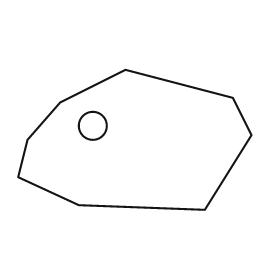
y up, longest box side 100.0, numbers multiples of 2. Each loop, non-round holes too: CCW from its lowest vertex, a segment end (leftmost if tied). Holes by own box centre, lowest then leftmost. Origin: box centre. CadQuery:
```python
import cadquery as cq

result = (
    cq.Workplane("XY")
    .moveTo(30.0, -30.0)
    .lineTo(50.0, 2.0)
    .lineTo(42.0, 18.0)
    .lineTo(-4.0, 30.0)
    .lineTo(-32.0, 16.0)
    .lineTo(-46.0, 0.0)
    .lineTo(-50.0, -16.0)
    .lineTo(-24.0, -28.0)
    .close()
    .moveTo(-18.0, 6.0)
    .circle(6.0)
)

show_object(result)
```